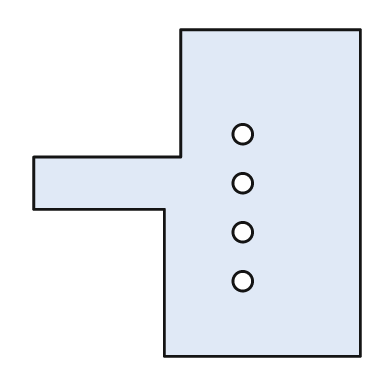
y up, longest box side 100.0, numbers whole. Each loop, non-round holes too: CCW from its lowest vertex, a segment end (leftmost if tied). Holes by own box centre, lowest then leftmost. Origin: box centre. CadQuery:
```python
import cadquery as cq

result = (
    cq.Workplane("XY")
    .moveTo(-10.0, -50.0)
    .lineTo(50.0, -50.0)
    .lineTo(50.0, 50.0)
    .lineTo(-5.0, 50.0)
    .lineTo(-5.0, 11.0)
    .lineTo(-50.0, 11.0)
    .lineTo(-50.0, -5.0)
    .lineTo(-10.0, -5.0)
    .close()
    .moveTo(14.0, -27.0)
    .circle(3.0)
    .moveTo(14.0, -12.0)
    .circle(3.0)
    .moveTo(14.0, 3.0)
    .circle(3.0)
    .moveTo(14.0, 18.0)
    .circle(3.0)
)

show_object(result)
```